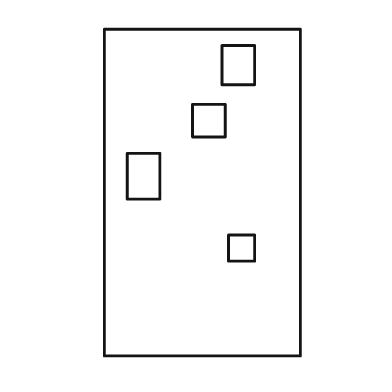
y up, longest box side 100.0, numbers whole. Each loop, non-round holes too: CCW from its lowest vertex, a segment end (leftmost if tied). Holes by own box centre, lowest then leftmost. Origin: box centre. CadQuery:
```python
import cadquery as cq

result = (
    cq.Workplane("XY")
    .moveTo(-30.0, -50.0)
    .lineTo(30.0, -50.0)
    .lineTo(30.0, 50.0)
    .lineTo(-30.0, 50.0)
    .close()
    .moveTo(8.0, -21.0)
    .lineTo(16.0, -21.0)
    .lineTo(16.0, -13.0)
    .lineTo(8.0, -13.0)
    .close()
    .moveTo(-23.0, -2.0)
    .lineTo(-13.0, -2.0)
    .lineTo(-13.0, 12.0)
    .lineTo(-23.0, 12.0)
    .close()
    .moveTo(-3.0, 17.0)
    .lineTo(7.0, 17.0)
    .lineTo(7.0, 27.0)
    .lineTo(-3.0, 27.0)
    .close()
    .moveTo(6.0, 33.0)
    .lineTo(16.0, 33.0)
    .lineTo(16.0, 45.0)
    .lineTo(6.0, 45.0)
    .close()
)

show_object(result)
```